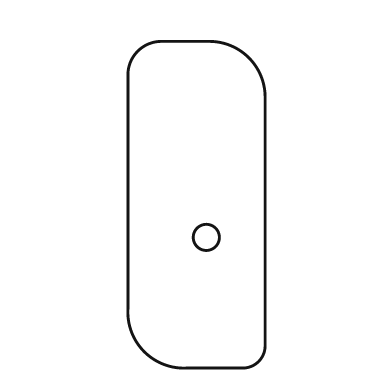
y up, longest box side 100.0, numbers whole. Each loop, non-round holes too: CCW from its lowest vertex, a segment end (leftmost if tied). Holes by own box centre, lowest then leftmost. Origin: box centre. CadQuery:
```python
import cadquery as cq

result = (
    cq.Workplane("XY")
    .moveTo(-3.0, -50.0)
    .lineTo(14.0, -50.0)
    .threePointArc((19.0, -48.0), (21.0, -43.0))
    .lineTo(21.0, 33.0)
    .threePointArc((16.0, 45.0), (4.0, 50.0))
    .lineTo(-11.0, 50.0)
    .threePointArc((-18.0, 47.0), (-21.0, 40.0))
    .lineTo(-21.0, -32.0)
    .threePointArc((-16.0, -45.0), (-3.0, -50.0))
    .close()
    .moveTo(3.0, -10.0)
    .circle(4.0)
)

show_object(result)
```